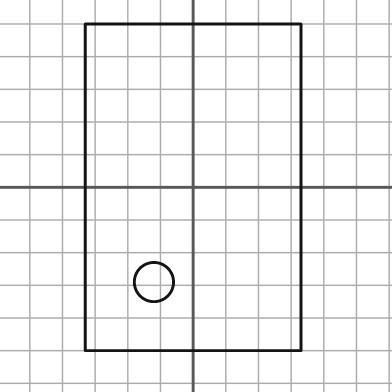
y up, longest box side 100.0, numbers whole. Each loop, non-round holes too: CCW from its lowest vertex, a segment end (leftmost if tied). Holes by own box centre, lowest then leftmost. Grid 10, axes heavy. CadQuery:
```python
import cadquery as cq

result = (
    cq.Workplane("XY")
    .moveTo(-33.0, -50.0)
    .lineTo(33.0, -50.0)
    .lineTo(33.0, 50.0)
    .lineTo(-33.0, 50.0)
    .close()
    .moveTo(-12.0, -29.0)
    .circle(6.0)
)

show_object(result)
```